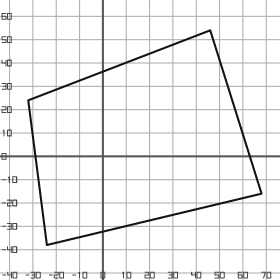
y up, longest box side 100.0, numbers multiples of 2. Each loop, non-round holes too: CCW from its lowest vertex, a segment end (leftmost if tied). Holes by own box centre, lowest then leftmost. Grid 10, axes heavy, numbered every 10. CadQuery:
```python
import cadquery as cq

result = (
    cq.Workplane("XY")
    .moveTo(-24.0, -38.0)
    .lineTo(68.0, -16.0)
    .lineTo(46.0, 54.0)
    .lineTo(-32.0, 24.0)
    .close()
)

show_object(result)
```